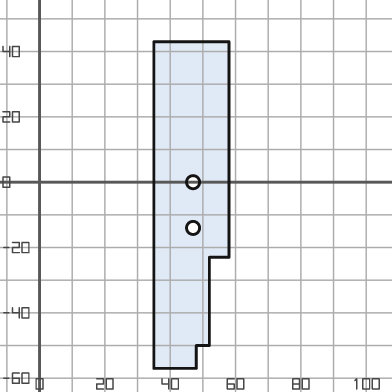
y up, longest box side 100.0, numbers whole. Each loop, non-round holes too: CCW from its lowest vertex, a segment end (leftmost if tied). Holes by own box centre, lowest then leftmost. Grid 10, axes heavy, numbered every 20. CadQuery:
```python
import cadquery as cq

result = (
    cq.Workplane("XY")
    .moveTo(35.0, -57.0)
    .lineTo(48.0, -57.0)
    .lineTo(48.0, -50.0)
    .lineTo(52.0, -50.0)
    .lineTo(52.0, -23.0)
    .lineTo(58.0, -23.0)
    .lineTo(58.0, 43.0)
    .lineTo(35.0, 43.0)
    .close()
    .moveTo(47.0, -14.0)
    .circle(2.0)
    .moveTo(47.0, 0.0)
    .circle(2.0)
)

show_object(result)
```